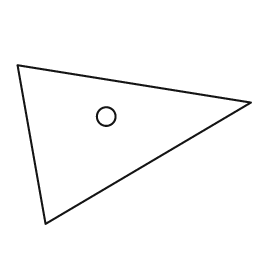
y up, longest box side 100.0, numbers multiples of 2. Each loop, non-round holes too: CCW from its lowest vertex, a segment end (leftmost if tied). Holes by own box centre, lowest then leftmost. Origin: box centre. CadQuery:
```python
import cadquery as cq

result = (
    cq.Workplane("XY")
    .moveTo(-38.0, -34.0)
    .lineTo(50.0, 18.0)
    .lineTo(-50.0, 34.0)
    .close()
    .moveTo(-12.0, 12.0)
    .circle(4.0)
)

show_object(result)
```